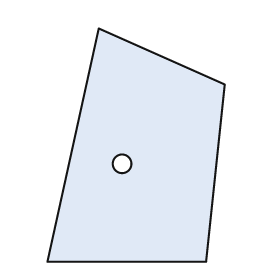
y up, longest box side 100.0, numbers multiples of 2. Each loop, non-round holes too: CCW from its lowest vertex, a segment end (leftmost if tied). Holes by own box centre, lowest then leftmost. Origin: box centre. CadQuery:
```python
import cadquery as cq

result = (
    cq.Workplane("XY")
    .moveTo(-38.0, -50.0)
    .lineTo(30.0, -50.0)
    .lineTo(38.0, 26.0)
    .lineTo(-16.0, 50.0)
    .close()
    .moveTo(-6.0, -8.0)
    .circle(4.0)
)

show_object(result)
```